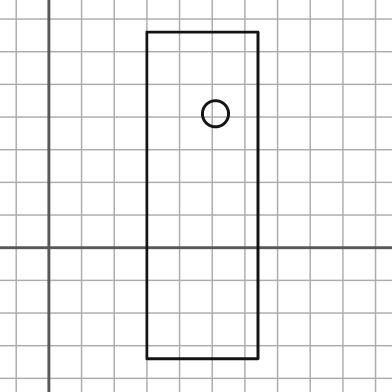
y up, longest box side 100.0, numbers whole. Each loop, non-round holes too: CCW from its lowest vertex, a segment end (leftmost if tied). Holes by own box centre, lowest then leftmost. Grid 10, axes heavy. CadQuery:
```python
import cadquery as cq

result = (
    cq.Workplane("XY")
    .moveTo(30.0, -34.0)
    .lineTo(64.0, -34.0)
    .lineTo(64.0, 66.0)
    .lineTo(30.0, 66.0)
    .close()
    .moveTo(51.0, 41.0)
    .circle(4.0)
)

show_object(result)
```